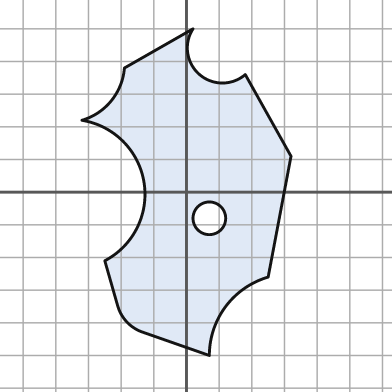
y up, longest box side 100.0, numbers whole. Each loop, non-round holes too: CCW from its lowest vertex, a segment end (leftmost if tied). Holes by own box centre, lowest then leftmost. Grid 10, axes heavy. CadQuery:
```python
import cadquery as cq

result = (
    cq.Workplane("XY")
    .moveTo(7.0, -50.0)
    .threePointArc((12.0, -35.0), (25.0, -26.0))
    .lineTo(32.0, 11.0)
    .lineTo(18.0, 36.0)
    .threePointArc((4.0, 36.0), (2.0, 50.0))
    .lineTo(-19.0, 38.0)
    .threePointArc((-23.0, 28.0), (-32.0, 22.0))
    .threePointArc((-13.0, 3.0), (-25.0, -21.0))
    .lineTo(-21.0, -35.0)
    .threePointArc((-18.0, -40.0), (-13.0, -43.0))
    .close()
    .moveTo(7.0, -8.0)
    .circle(5.0)
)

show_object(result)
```